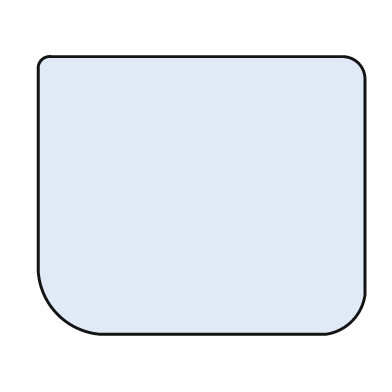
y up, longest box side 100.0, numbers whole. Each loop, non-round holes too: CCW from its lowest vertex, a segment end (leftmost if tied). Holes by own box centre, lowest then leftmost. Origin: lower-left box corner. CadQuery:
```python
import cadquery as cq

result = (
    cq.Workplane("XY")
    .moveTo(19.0, 0.0)
    .lineTo(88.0, 0.0)
    .threePointArc((96.0, 4.0), (100.0, 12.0))
    .lineTo(100.0, 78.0)
    .threePointArc((98.0, 83.0), (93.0, 85.0))
    .lineTo(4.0, 85.0)
    .threePointArc((1.0, 84.0), (0.0, 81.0))
    .lineTo(0.0, 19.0)
    .threePointArc((6.0, 6.0), (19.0, 0.0))
    .close()
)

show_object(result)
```